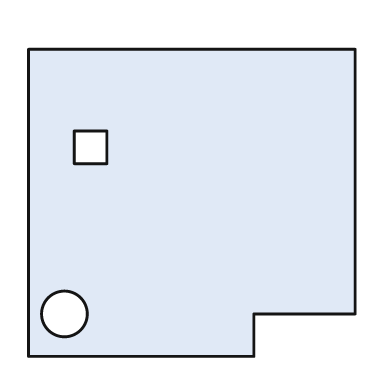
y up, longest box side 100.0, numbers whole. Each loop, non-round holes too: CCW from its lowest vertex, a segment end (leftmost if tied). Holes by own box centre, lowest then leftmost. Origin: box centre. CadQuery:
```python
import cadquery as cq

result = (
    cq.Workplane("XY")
    .moveTo(-50.0, -47.0)
    .lineTo(19.0, -47.0)
    .lineTo(19.0, -34.0)
    .lineTo(50.0, -34.0)
    .lineTo(50.0, 47.0)
    .lineTo(-50.0, 47.0)
    .close()
    .moveTo(-39.0, -34.0)
    .circle(7.0)
    .moveTo(-36.0, 12.0)
    .lineTo(-26.0, 12.0)
    .lineTo(-26.0, 22.0)
    .lineTo(-36.0, 22.0)
    .close()
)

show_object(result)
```